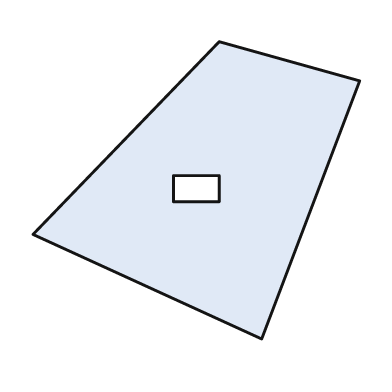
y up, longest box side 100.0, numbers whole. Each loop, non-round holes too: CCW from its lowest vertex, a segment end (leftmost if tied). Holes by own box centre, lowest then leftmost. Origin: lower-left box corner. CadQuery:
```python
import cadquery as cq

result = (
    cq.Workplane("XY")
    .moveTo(70.0, 0.0)
    .lineTo(100.0, 79.0)
    .lineTo(57.0, 91.0)
    .lineTo(0.0, 32.0)
    .close()
    .moveTo(43.0, 42.0)
    .lineTo(57.0, 42.0)
    .lineTo(57.0, 50.0)
    .lineTo(43.0, 50.0)
    .close()
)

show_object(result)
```